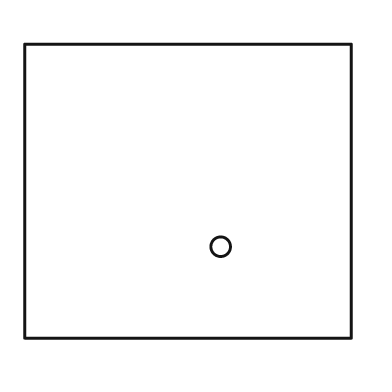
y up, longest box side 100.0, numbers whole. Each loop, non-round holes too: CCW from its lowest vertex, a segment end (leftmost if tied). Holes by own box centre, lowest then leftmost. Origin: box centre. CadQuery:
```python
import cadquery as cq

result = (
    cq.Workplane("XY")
    .moveTo(-50.0, -45.0)
    .lineTo(50.0, -45.0)
    .lineTo(50.0, 45.0)
    .lineTo(-50.0, 45.0)
    .close()
    .moveTo(10.0, -17.0)
    .circle(3.0)
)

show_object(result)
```